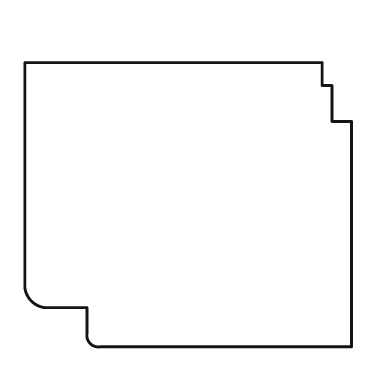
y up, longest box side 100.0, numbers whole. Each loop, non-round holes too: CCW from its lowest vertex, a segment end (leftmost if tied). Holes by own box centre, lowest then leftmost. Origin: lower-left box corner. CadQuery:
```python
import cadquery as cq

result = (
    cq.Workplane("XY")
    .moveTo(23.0, 0.0)
    .lineTo(100.0, 0.0)
    .lineTo(100.0, 69.0)
    .lineTo(94.0, 69.0)
    .lineTo(94.0, 80.0)
    .lineTo(91.0, 80.0)
    .lineTo(91.0, 87.0)
    .lineTo(0.0, 87.0)
    .lineTo(0.0, 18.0)
    .threePointArc((2.0, 14.0), (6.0, 12.0))
    .lineTo(19.0, 12.0)
    .lineTo(19.0, 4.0)
    .threePointArc((20.0, 1.0), (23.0, 0.0))
    .close()
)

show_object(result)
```